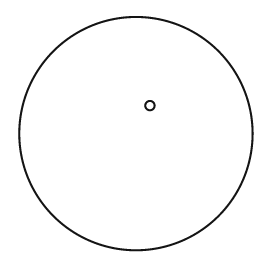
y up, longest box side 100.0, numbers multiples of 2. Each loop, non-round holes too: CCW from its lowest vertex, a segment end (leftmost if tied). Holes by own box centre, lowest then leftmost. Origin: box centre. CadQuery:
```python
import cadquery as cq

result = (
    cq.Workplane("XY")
    .moveTo(0.0, 0.0)
    .circle(50.0)
    .moveTo(6.0, 12.0)
    .circle(2.0)
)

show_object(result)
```